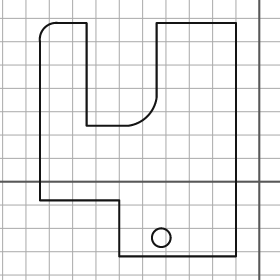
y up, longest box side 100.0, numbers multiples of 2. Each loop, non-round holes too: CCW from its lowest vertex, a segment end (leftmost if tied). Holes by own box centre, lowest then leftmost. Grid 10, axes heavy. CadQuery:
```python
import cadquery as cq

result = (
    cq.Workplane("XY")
    .moveTo(-60.0, -32.0)
    .lineTo(-10.0, -32.0)
    .lineTo(-10.0, 68.0)
    .lineTo(-44.0, 68.0)
    .lineTo(-44.0, 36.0)
    .threePointArc((-48.0, 28.0), (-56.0, 24.0))
    .lineTo(-74.0, 24.0)
    .lineTo(-74.0, 68.0)
    .lineTo(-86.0, 68.0)
    .threePointArc((-92.0, 66.0), (-94.0, 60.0))
    .lineTo(-94.0, -8.0)
    .lineTo(-60.0, -8.0)
    .close()
    .moveTo(-42.0, -24.0)
    .circle(4.0)
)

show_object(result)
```